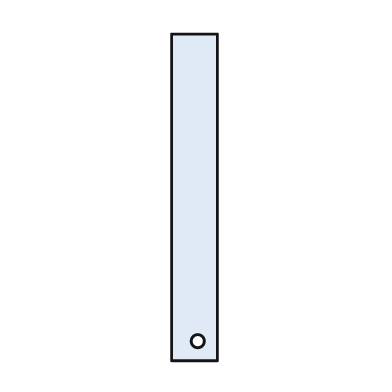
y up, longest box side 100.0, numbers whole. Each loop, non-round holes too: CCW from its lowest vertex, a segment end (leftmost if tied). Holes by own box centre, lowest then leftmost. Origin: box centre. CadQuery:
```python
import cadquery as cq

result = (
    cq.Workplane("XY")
    .moveTo(-7.0, -50.0)
    .lineTo(7.0, -50.0)
    .lineTo(7.0, 50.0)
    .lineTo(-7.0, 50.0)
    .close()
    .moveTo(1.0, -44.0)
    .circle(2.0)
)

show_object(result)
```